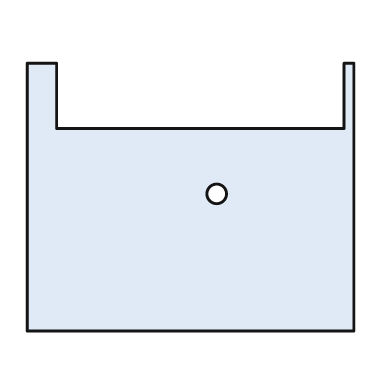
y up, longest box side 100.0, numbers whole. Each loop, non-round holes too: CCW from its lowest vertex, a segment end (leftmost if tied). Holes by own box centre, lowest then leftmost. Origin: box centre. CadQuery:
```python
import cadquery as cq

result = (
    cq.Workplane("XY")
    .moveTo(-50.0, -41.0)
    .lineTo(50.0, -41.0)
    .lineTo(50.0, 41.0)
    .lineTo(47.0, 41.0)
    .lineTo(47.0, 21.0)
    .lineTo(-41.0, 21.0)
    .lineTo(-41.0, 41.0)
    .lineTo(-50.0, 41.0)
    .close()
    .moveTo(8.0, 1.0)
    .circle(3.0)
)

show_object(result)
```